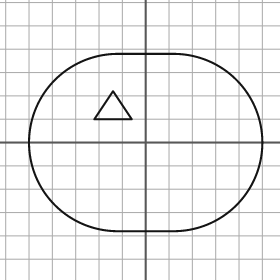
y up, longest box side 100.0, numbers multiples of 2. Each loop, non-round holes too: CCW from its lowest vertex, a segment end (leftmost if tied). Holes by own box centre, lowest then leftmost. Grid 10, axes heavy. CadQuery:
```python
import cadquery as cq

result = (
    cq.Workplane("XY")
    .moveTo(-12.0, -38.0)
    .lineTo(12.0, -38.0)
    .threePointArc((50.0, 0.0), (12.0, 38.0))
    .lineTo(-12.0, 38.0)
    .threePointArc((-50.0, 0.0), (-12.0, -38.0))
    .close()
    .moveTo(-22.0, 10.0)
    .lineTo(-6.0, 10.0)
    .lineTo(-14.0, 22.0)
    .close()
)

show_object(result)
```